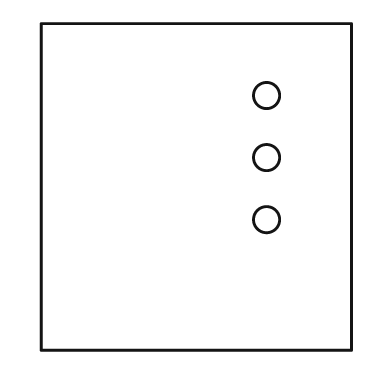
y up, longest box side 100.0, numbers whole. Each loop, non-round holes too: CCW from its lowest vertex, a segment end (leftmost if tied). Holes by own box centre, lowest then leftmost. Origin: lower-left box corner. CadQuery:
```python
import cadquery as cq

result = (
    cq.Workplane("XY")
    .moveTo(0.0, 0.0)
    .lineTo(95.0, 0.0)
    .lineTo(95.0, 100.0)
    .lineTo(0.0, 100.0)
    .close()
    .moveTo(69.0, 40.0)
    .circle(4.0)
    .moveTo(69.0, 59.0)
    .circle(4.0)
    .moveTo(69.0, 78.0)
    .circle(4.0)
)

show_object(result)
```